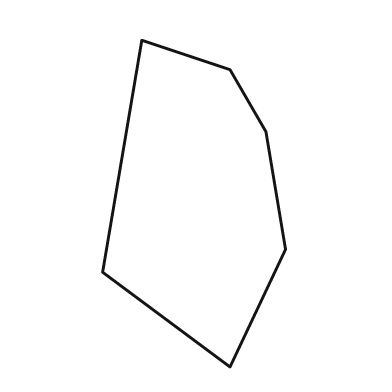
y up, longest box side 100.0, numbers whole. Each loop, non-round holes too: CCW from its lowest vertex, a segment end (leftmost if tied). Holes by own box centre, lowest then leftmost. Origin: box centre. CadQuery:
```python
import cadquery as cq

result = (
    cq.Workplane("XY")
    .moveTo(11.0, -50.0)
    .lineTo(28.0, -14.0)
    .lineTo(22.0, 22.0)
    .lineTo(11.0, 41.0)
    .lineTo(-16.0, 50.0)
    .lineTo(-28.0, -21.0)
    .close()
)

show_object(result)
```